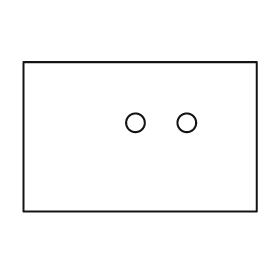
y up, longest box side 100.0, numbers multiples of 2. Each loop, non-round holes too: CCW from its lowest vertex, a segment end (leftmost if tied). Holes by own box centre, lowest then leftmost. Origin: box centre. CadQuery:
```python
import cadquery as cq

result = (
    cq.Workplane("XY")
    .moveTo(-50.0, -32.0)
    .lineTo(50.0, -32.0)
    .lineTo(50.0, 32.0)
    .lineTo(-50.0, 32.0)
    .close()
    .moveTo(-2.0, 6.0)
    .circle(4.0)
    .moveTo(20.0, 6.0)
    .circle(4.0)
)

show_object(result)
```